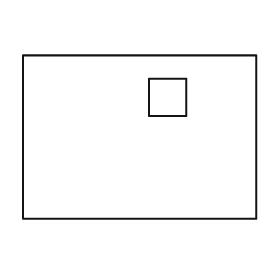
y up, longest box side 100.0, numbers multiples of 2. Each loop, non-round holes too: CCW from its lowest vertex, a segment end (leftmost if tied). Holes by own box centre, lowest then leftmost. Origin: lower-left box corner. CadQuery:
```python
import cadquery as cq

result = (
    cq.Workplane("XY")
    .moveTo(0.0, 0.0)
    .lineTo(100.0, 0.0)
    .lineTo(100.0, 70.0)
    .lineTo(0.0, 70.0)
    .close()
    .moveTo(54.0, 44.0)
    .lineTo(70.0, 44.0)
    .lineTo(70.0, 60.0)
    .lineTo(54.0, 60.0)
    .close()
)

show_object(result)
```